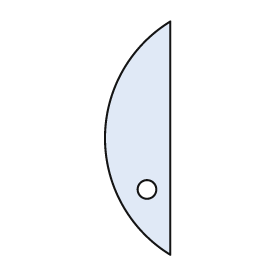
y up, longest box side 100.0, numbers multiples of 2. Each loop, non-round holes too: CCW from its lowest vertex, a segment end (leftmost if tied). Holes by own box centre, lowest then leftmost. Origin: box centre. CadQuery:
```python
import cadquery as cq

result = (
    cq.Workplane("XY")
    .moveTo(14.0, -50.0)
    .lineTo(14.0, 50.0)
    .threePointArc((-14.0, 0.0), (14.0, -50.0))
    .close()
    .moveTo(4.0, -22.0)
    .circle(4.0)
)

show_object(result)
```